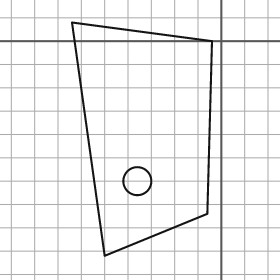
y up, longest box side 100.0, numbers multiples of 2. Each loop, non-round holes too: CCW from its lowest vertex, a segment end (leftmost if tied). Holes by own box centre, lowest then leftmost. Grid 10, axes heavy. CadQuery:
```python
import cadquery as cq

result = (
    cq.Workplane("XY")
    .moveTo(-50.0, -92.0)
    .lineTo(-6.0, -74.0)
    .lineTo(-4.0, 0.0)
    .lineTo(-64.0, 8.0)
    .close()
    .moveTo(-36.0, -60.0)
    .circle(6.0)
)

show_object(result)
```